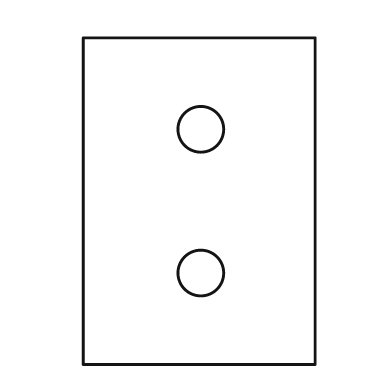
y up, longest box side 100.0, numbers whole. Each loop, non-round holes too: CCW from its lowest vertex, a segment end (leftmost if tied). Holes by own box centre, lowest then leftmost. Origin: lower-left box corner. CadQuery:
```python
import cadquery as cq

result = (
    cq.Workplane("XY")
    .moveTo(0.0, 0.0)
    .lineTo(71.0, 0.0)
    .lineTo(71.0, 100.0)
    .lineTo(0.0, 100.0)
    .close()
    .moveTo(36.0, 28.0)
    .circle(7.0)
    .moveTo(36.0, 72.0)
    .circle(7.0)
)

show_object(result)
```